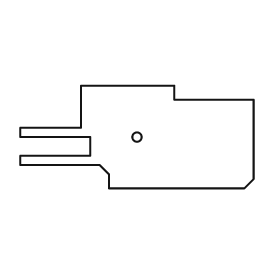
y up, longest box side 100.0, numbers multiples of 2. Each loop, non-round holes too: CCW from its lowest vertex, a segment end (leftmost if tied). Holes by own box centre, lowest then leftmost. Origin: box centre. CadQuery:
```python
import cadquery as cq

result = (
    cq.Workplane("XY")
    .moveTo(-12.0, -22.0)
    .lineTo(46.0, -22.0)
    .lineTo(50.0, -18.0)
    .lineTo(50.0, 16.0)
    .lineTo(16.0, 16.0)
    .lineTo(16.0, 22.0)
    .lineTo(-24.0, 22.0)
    .lineTo(-24.0, 4.0)
    .lineTo(-50.0, 4.0)
    .lineTo(-50.0, 0.0)
    .lineTo(-20.0, 0.0)
    .lineTo(-20.0, -8.0)
    .lineTo(-50.0, -8.0)
    .lineTo(-50.0, -12.0)
    .lineTo(-16.0, -12.0)
    .lineTo(-12.0, -16.0)
    .close()
    .moveTo(0.0, 0.0)
    .circle(2.0)
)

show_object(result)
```